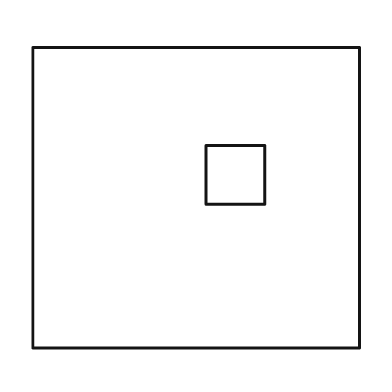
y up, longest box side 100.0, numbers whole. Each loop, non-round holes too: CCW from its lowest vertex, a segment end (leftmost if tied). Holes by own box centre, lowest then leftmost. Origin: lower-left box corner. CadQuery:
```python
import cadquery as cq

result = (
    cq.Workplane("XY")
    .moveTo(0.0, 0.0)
    .lineTo(100.0, 0.0)
    .lineTo(100.0, 92.0)
    .lineTo(0.0, 92.0)
    .close()
    .moveTo(53.0, 44.0)
    .lineTo(71.0, 44.0)
    .lineTo(71.0, 62.0)
    .lineTo(53.0, 62.0)
    .close()
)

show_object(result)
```